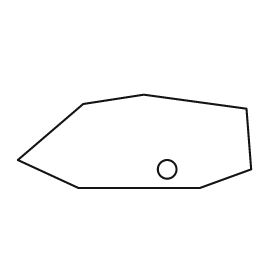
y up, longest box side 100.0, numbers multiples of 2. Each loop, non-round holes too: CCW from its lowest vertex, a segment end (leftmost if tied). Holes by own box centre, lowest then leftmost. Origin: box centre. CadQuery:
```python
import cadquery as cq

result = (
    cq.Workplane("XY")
    .moveTo(-24.0, -20.0)
    .lineTo(28.0, -20.0)
    .lineTo(50.0, -12.0)
    .lineTo(48.0, 14.0)
    .lineTo(4.0, 20.0)
    .lineTo(-22.0, 16.0)
    .lineTo(-50.0, -8.0)
    .close()
    .moveTo(14.0, -12.0)
    .circle(4.0)
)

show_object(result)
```